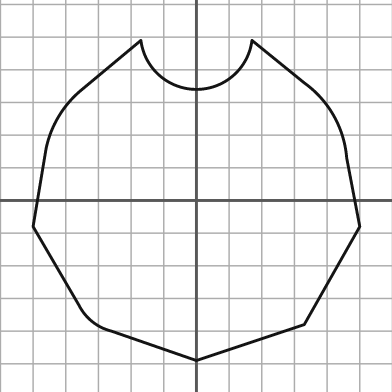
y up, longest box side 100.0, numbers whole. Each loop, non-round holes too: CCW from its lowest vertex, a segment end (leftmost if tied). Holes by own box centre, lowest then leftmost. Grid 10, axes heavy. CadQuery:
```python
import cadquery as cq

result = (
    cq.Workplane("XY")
    .moveTo(0.0, -49.0)
    .lineTo(33.0, -38.0)
    .lineTo(50.0, -8.0)
    .lineTo(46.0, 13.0)
    .threePointArc((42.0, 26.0), (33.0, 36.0))
    .lineTo(17.0, 49.0)
    .threePointArc((0.0, 34.0), (-17.0, 49.0))
    .lineTo(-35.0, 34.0)
    .threePointArc((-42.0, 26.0), (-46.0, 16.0))
    .lineTo(-50.0, -8.0)
    .lineTo(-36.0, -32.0)
    .threePointArc((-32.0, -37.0), (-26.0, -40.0))
    .close()
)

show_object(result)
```